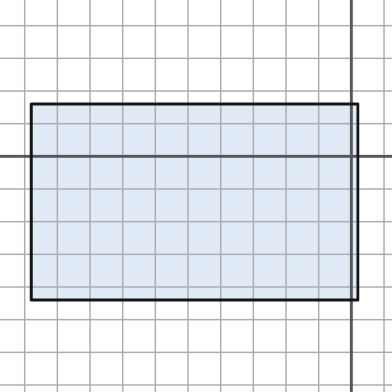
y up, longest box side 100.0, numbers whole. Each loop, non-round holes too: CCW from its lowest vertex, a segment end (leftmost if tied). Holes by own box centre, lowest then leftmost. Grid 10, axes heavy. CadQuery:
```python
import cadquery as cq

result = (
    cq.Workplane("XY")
    .moveTo(-98.0, -44.0)
    .lineTo(2.0, -44.0)
    .lineTo(2.0, 16.0)
    .lineTo(-98.0, 16.0)
    .close()
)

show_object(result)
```